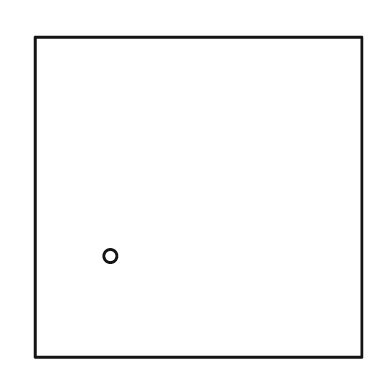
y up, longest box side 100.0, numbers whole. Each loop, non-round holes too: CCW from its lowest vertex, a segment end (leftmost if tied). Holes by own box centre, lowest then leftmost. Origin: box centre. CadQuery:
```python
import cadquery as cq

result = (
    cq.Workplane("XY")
    .moveTo(-50.0, -49.0)
    .lineTo(50.0, -49.0)
    .lineTo(50.0, 49.0)
    .lineTo(-50.0, 49.0)
    .close()
    .moveTo(-27.0, -18.0)
    .circle(2.0)
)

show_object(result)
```